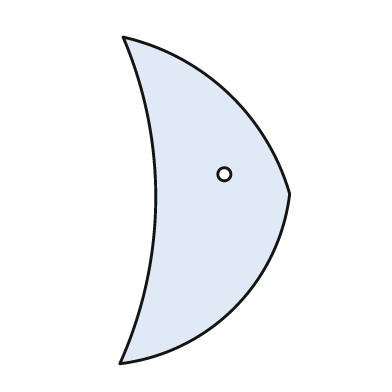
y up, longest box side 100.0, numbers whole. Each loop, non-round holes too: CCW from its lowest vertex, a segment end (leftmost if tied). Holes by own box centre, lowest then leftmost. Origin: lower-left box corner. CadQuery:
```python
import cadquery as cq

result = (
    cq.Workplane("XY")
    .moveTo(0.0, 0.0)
    .threePointArc((35.0, 17.0), (52.0, 52.0))
    .threePointArc((33.0, 83.0), (1.0, 100.0))
    .threePointArc((11.0, 50.0), (0.0, 0.0))
    .close()
    .moveTo(32.0, 58.0)
    .circle(2.0)
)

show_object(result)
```